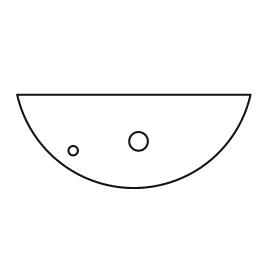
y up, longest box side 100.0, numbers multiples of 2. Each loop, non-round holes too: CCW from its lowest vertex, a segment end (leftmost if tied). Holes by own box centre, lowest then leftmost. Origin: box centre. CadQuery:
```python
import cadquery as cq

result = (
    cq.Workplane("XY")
    .moveTo(-50.0, 20.0)
    .threePointArc((0.0, -20.0), (50.0, 20.0))
    .close()
    .moveTo(-26.0, -4.0)
    .circle(2.0)
    .moveTo(2.0, 0.0)
    .circle(4.0)
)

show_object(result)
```